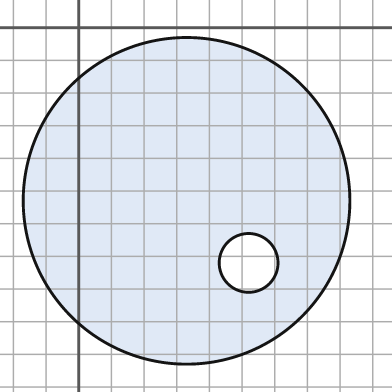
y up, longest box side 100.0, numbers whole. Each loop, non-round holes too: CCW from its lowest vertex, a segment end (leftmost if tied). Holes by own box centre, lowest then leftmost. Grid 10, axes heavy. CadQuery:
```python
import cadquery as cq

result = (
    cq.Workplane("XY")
    .moveTo(33.0, -53.0)
    .circle(50.0)
    .moveTo(52.0, -72.0)
    .circle(9.0)
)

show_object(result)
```